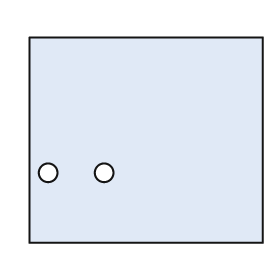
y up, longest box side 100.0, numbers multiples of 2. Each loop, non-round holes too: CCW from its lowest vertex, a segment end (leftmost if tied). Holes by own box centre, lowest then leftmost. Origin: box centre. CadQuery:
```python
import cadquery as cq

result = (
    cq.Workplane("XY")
    .moveTo(-50.0, -44.0)
    .lineTo(50.0, -44.0)
    .lineTo(50.0, 44.0)
    .lineTo(-50.0, 44.0)
    .close()
    .moveTo(-42.0, -14.0)
    .circle(4.0)
    .moveTo(-18.0, -14.0)
    .circle(4.0)
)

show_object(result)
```